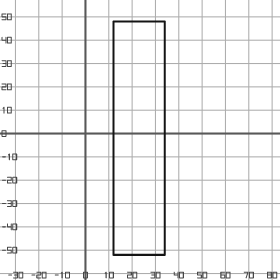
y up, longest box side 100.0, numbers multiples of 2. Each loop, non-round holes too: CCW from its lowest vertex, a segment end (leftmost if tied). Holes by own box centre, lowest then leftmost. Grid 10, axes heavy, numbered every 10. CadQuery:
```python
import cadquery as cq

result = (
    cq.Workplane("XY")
    .moveTo(12.0, -52.0)
    .lineTo(34.0, -52.0)
    .lineTo(34.0, 48.0)
    .lineTo(12.0, 48.0)
    .close()
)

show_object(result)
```